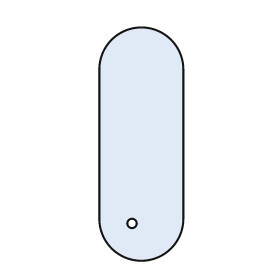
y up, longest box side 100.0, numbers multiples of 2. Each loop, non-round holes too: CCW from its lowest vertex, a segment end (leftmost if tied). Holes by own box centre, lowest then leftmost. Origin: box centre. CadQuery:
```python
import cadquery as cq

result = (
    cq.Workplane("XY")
    .moveTo(-18.0, -32.0)
    .threePointArc((0.0, -50.0), (18.0, -32.0))
    .lineTo(18.0, 32.0)
    .threePointArc((0.0, 50.0), (-18.0, 32.0))
    .close()
    .moveTo(-4.0, -34.0)
    .circle(2.0)
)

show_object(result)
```